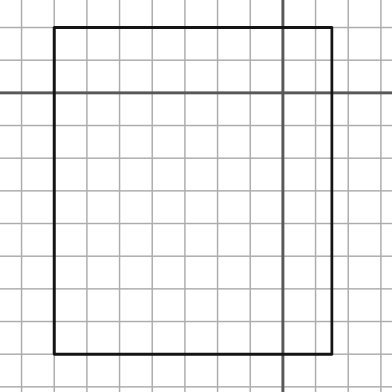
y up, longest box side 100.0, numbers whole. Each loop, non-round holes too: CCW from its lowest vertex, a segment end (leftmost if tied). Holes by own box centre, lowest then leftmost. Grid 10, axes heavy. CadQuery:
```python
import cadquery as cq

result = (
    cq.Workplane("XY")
    .moveTo(-70.0, -80.0)
    .lineTo(15.0, -80.0)
    .lineTo(15.0, 20.0)
    .lineTo(-70.0, 20.0)
    .close()
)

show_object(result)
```